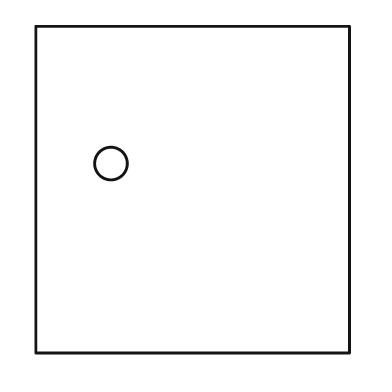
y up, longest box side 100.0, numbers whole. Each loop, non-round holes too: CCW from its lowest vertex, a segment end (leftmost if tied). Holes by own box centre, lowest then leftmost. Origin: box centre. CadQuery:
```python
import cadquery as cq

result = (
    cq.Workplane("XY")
    .moveTo(-48.0, -50.0)
    .lineTo(48.0, -50.0)
    .lineTo(48.0, 50.0)
    .lineTo(-48.0, 50.0)
    .close()
    .moveTo(-25.0, 8.0)
    .circle(5.0)
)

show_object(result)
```